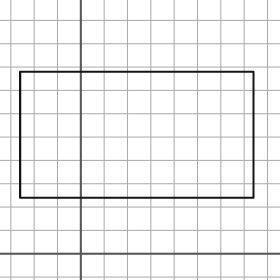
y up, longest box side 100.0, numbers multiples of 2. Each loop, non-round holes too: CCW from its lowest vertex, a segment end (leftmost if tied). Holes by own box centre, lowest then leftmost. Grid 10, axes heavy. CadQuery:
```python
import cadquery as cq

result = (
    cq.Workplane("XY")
    .moveTo(-26.0, 24.0)
    .lineTo(74.0, 24.0)
    .lineTo(74.0, 78.0)
    .lineTo(-26.0, 78.0)
    .close()
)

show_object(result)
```